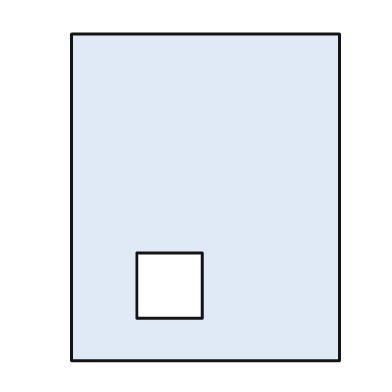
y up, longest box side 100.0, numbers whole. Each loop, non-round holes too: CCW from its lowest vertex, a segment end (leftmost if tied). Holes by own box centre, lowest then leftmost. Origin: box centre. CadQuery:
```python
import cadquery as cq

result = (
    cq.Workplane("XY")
    .moveTo(-41.0, -50.0)
    .lineTo(41.0, -50.0)
    .lineTo(41.0, 50.0)
    .lineTo(-41.0, 50.0)
    .close()
    .moveTo(-21.0, -37.0)
    .lineTo(-1.0, -37.0)
    .lineTo(-1.0, -17.0)
    .lineTo(-21.0, -17.0)
    .close()
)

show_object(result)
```